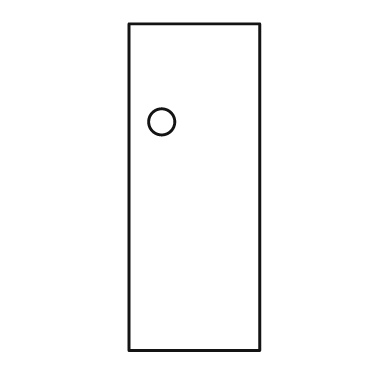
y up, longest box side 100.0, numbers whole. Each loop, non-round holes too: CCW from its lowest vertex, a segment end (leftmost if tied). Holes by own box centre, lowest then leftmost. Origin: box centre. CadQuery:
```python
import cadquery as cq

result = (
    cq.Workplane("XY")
    .moveTo(-20.0, -50.0)
    .lineTo(20.0, -50.0)
    .lineTo(20.0, 50.0)
    .lineTo(-20.0, 50.0)
    .close()
    .moveTo(-10.0, 20.0)
    .circle(4.0)
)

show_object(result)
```